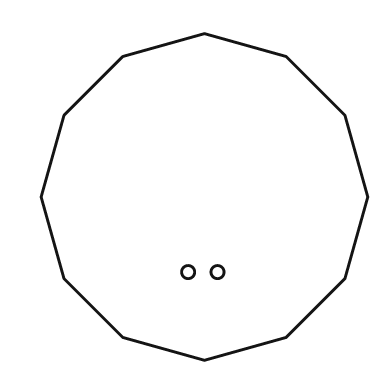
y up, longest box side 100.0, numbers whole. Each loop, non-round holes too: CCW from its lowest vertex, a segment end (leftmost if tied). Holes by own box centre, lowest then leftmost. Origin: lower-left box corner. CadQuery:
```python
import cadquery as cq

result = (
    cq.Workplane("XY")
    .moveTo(50.0, 0.0)
    .lineTo(75.0, 7.0)
    .lineTo(93.0, 25.0)
    .lineTo(100.0, 50.0)
    .lineTo(93.0, 75.0)
    .lineTo(75.0, 93.0)
    .lineTo(50.0, 100.0)
    .lineTo(25.0, 93.0)
    .lineTo(7.0, 75.0)
    .lineTo(0.0, 50.0)
    .lineTo(7.0, 25.0)
    .lineTo(25.0, 7.0)
    .close()
    .moveTo(45.0, 27.0)
    .circle(2.0)
    .moveTo(54.0, 27.0)
    .circle(2.0)
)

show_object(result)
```